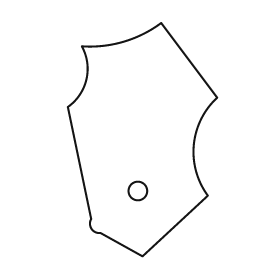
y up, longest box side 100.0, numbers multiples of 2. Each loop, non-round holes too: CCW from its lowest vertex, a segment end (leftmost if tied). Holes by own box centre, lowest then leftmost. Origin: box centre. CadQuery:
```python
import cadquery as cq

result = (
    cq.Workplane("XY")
    .moveTo(0.0, -50.0)
    .lineTo(28.0, -24.0)
    .threePointArc((22.0, -2.0), (32.0, 18.0))
    .lineTo(8.0, 50.0)
    .threePointArc((-8.0, 42.0), (-26.0, 40.0))
    .threePointArc((-24.0, 26.0), (-32.0, 14.0))
    .lineTo(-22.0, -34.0)
    .threePointArc((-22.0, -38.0), (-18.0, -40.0))
    .close()
    .moveTo(-2.0, -22.0)
    .circle(4.0)
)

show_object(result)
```